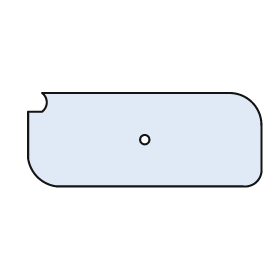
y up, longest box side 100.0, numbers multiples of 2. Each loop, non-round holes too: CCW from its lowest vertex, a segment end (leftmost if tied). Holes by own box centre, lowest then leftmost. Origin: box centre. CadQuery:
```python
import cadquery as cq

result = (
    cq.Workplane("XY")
    .moveTo(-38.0, -20.0)
    .lineTo(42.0, -20.0)
    .threePointArc((48.0, -18.0), (50.0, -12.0))
    .lineTo(50.0, 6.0)
    .threePointArc((46.0, 16.0), (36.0, 20.0))
    .lineTo(-44.0, 20.0)
    .threePointArc((-42.0, 16.0), (-44.0, 12.0))
    .lineTo(-50.0, 12.0)
    .lineTo(-50.0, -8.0)
    .threePointArc((-46.0, -16.0), (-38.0, -20.0))
    .close()
    .moveTo(0.0, 0.0)
    .circle(2.0)
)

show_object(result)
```